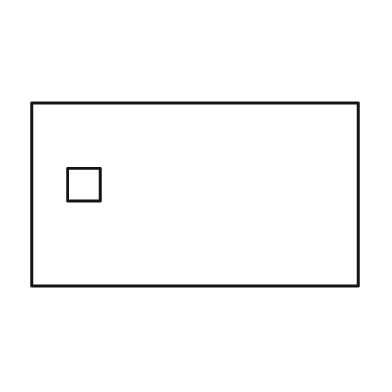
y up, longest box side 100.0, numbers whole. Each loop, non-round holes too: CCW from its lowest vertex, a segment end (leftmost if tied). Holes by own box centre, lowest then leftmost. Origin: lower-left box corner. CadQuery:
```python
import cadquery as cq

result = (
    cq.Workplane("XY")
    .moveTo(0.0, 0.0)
    .lineTo(100.0, 0.0)
    .lineTo(100.0, 56.0)
    .lineTo(0.0, 56.0)
    .close()
    .moveTo(11.0, 26.0)
    .lineTo(21.0, 26.0)
    .lineTo(21.0, 36.0)
    .lineTo(11.0, 36.0)
    .close()
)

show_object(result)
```